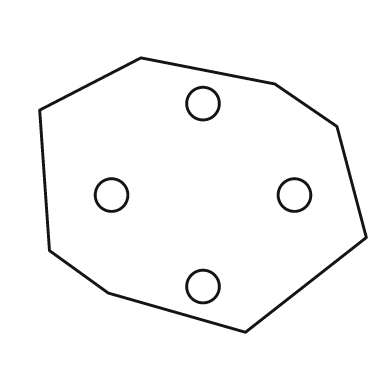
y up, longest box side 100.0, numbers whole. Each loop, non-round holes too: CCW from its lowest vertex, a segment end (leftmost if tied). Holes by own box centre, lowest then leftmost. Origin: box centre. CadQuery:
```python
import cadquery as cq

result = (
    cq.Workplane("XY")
    .moveTo(13.0, -42.0)
    .lineTo(50.0, -13.0)
    .lineTo(41.0, 21.0)
    .lineTo(22.0, 34.0)
    .lineTo(-19.0, 42.0)
    .lineTo(-50.0, 26.0)
    .lineTo(-47.0, -17.0)
    .lineTo(-29.0, -30.0)
    .close()
    .moveTo(0.0, -28.0)
    .circle(5.0)
    .moveTo(-28.0, 0.0)
    .circle(5.0)
    .moveTo(28.0, 0.0)
    .circle(5.0)
    .moveTo(0.0, 28.0)
    .circle(5.0)
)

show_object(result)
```